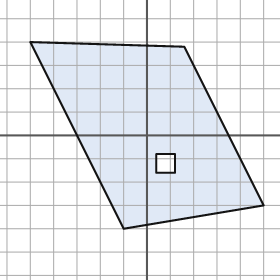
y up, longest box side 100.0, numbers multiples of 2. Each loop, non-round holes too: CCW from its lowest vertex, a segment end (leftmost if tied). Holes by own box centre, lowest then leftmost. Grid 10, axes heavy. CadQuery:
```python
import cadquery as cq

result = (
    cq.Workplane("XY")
    .moveTo(-10.0, -40.0)
    .lineTo(50.0, -30.0)
    .lineTo(16.0, 38.0)
    .lineTo(-50.0, 40.0)
    .close()
    .moveTo(4.0, -16.0)
    .lineTo(12.0, -16.0)
    .lineTo(12.0, -8.0)
    .lineTo(4.0, -8.0)
    .close()
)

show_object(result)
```